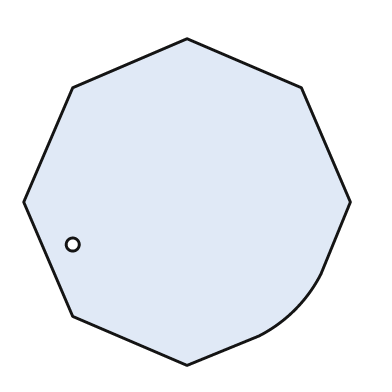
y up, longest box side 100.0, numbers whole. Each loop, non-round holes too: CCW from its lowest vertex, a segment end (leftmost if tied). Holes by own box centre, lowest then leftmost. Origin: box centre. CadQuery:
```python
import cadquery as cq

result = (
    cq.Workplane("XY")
    .moveTo(0.0, -50.0)
    .lineTo(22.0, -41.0)
    .threePointArc((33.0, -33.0), (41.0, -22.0))
    .lineTo(50.0, 0.0)
    .lineTo(35.0, 35.0)
    .lineTo(0.0, 50.0)
    .lineTo(-35.0, 35.0)
    .lineTo(-50.0, 0.0)
    .lineTo(-35.0, -35.0)
    .close()
    .moveTo(-35.0, -13.0)
    .circle(2.0)
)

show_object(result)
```